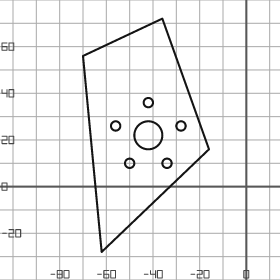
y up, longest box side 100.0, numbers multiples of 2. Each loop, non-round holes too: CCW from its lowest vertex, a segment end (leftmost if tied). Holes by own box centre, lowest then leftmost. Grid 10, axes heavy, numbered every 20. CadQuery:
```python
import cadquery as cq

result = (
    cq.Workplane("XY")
    .moveTo(-62.0, -28.0)
    .lineTo(-16.0, 16.0)
    .lineTo(-36.0, 72.0)
    .lineTo(-70.0, 56.0)
    .close()
    .moveTo(-50.0, 10.0)
    .circle(2.0)
    .moveTo(-34.0, 10.0)
    .circle(2.0)
    .moveTo(-42.0, 22.0)
    .circle(6.0)
    .moveTo(-56.0, 26.0)
    .circle(2.0)
    .moveTo(-28.0, 26.0)
    .circle(2.0)
    .moveTo(-42.0, 36.0)
    .circle(2.0)
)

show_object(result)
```